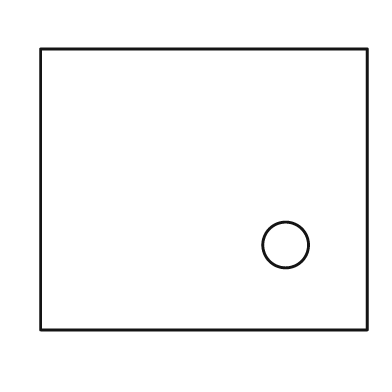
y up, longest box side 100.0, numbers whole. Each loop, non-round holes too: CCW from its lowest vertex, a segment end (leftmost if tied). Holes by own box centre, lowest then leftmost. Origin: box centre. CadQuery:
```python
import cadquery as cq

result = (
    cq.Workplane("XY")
    .moveTo(-50.0, -43.0)
    .lineTo(50.0, -43.0)
    .lineTo(50.0, 43.0)
    .lineTo(-50.0, 43.0)
    .close()
    .moveTo(25.0, -17.0)
    .circle(7.0)
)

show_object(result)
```